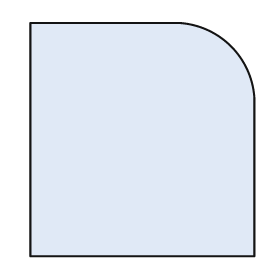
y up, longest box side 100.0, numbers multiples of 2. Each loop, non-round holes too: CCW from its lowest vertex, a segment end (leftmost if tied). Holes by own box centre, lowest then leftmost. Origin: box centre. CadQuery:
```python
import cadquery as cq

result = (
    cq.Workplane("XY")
    .moveTo(-48.0, -50.0)
    .lineTo(48.0, -50.0)
    .lineTo(48.0, 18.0)
    .threePointArc((38.0, 40.0), (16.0, 50.0))
    .lineTo(-48.0, 50.0)
    .close()
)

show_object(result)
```